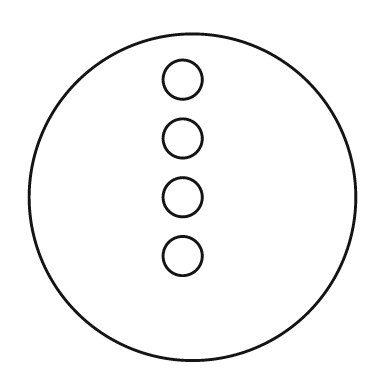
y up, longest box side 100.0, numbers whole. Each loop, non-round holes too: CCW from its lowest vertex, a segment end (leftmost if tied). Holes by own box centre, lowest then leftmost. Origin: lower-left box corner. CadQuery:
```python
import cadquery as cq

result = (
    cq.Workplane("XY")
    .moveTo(50.0, 50.0)
    .circle(50.0)
    .moveTo(47.0, 32.0)
    .circle(6.0)
    .moveTo(47.0, 50.0)
    .circle(6.0)
    .moveTo(47.0, 68.0)
    .circle(6.0)
    .moveTo(47.0, 86.0)
    .circle(6.0)
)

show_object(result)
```